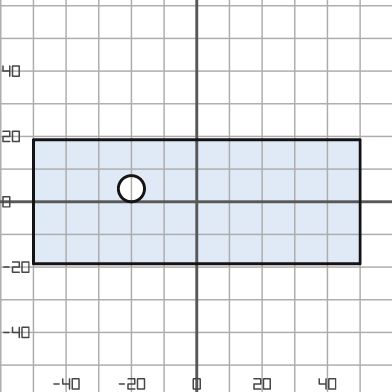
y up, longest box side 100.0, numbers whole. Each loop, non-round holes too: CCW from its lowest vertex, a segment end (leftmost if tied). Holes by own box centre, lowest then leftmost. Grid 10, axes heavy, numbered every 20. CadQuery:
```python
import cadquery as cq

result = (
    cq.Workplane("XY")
    .moveTo(-50.0, -19.0)
    .lineTo(50.0, -19.0)
    .lineTo(50.0, 19.0)
    .lineTo(-50.0, 19.0)
    .close()
    .moveTo(-20.0, 4.0)
    .circle(4.0)
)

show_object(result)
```